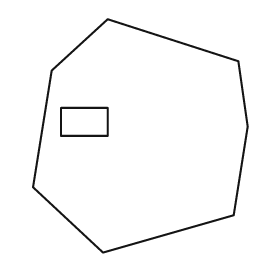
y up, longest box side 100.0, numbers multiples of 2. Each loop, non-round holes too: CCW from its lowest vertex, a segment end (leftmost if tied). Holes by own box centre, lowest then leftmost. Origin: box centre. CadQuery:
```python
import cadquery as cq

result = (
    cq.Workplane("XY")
    .moveTo(-16.0, -50.0)
    .lineTo(40.0, -34.0)
    .lineTo(46.0, 4.0)
    .lineTo(42.0, 32.0)
    .lineTo(-14.0, 50.0)
    .lineTo(-38.0, 28.0)
    .lineTo(-46.0, -22.0)
    .close()
    .moveTo(-34.0, 0.0)
    .lineTo(-14.0, 0.0)
    .lineTo(-14.0, 12.0)
    .lineTo(-34.0, 12.0)
    .close()
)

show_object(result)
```